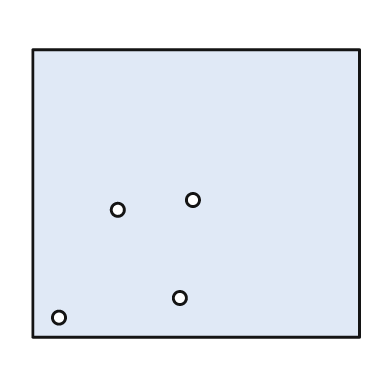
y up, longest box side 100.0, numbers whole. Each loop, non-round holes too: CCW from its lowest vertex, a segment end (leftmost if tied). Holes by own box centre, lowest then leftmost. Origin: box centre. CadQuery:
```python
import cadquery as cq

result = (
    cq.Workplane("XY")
    .moveTo(-50.0, -44.0)
    .lineTo(50.0, -44.0)
    .lineTo(50.0, 44.0)
    .lineTo(-50.0, 44.0)
    .close()
    .moveTo(-42.0, -38.0)
    .circle(2.0)
    .moveTo(-5.0, -32.0)
    .circle(2.0)
    .moveTo(-24.0, -5.0)
    .circle(2.0)
    .moveTo(-1.0, -2.0)
    .circle(2.0)
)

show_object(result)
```